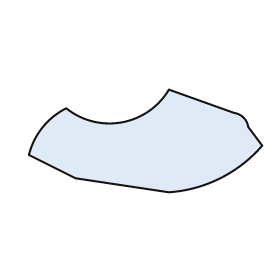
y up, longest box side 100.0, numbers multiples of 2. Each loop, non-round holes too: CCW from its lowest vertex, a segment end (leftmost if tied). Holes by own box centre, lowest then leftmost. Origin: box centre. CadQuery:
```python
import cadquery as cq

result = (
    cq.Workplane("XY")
    .moveTo(10.0, -22.0)
    .threePointArc((32.0, -16.0), (50.0, -2.0))
    .lineTo(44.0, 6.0)
    .threePointArc((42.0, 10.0), (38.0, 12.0))
    .lineTo(10.0, 22.0)
    .threePointArc((-10.0, 8.0), (-34.0, 14.0))
    .threePointArc((-44.0, 6.0), (-50.0, -6.0))
    .lineTo(-30.0, -16.0)
    .close()
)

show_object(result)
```